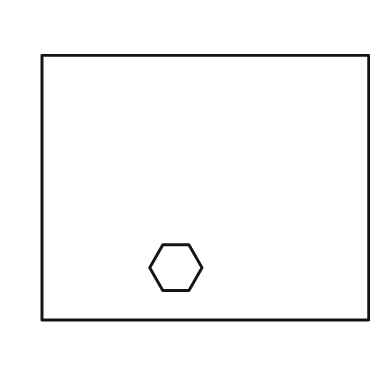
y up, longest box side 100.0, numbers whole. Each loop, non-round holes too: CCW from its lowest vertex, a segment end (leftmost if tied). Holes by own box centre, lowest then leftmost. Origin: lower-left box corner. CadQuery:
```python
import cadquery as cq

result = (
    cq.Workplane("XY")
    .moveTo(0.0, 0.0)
    .lineTo(100.0, 0.0)
    .lineTo(100.0, 81.0)
    .lineTo(0.0, 81.0)
    .close()
    .moveTo(37.0, 9.0)
    .lineTo(45.0, 9.0)
    .lineTo(49.0, 16.0)
    .lineTo(45.0, 23.0)
    .lineTo(37.0, 23.0)
    .lineTo(33.0, 16.0)
    .close()
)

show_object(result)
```